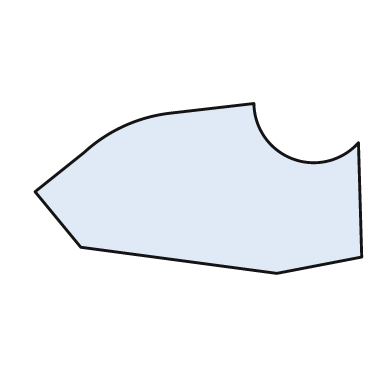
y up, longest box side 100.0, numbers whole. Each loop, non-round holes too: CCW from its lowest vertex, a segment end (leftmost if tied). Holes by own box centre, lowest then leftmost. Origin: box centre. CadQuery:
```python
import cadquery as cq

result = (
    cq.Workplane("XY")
    .moveTo(24.0, -26.0)
    .lineTo(50.0, -21.0)
    .lineTo(49.0, 14.0)
    .threePointArc((29.0, 9.0), (17.0, 26.0))
    .lineTo(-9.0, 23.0)
    .threePointArc((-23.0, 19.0), (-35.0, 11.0))
    .lineTo(-50.0, -1.0)
    .lineTo(-36.0, -18.0)
    .close()
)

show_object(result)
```